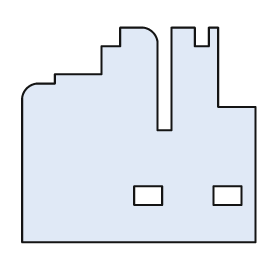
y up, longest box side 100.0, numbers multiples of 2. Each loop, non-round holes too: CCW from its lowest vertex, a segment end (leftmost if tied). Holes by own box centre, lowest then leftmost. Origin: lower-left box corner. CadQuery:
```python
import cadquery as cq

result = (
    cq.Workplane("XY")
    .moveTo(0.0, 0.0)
    .lineTo(100.0, 0.0)
    .lineTo(100.0, 58.0)
    .lineTo(84.0, 58.0)
    .lineTo(84.0, 92.0)
    .lineTo(80.0, 92.0)
    .lineTo(80.0, 84.0)
    .lineTo(74.0, 84.0)
    .lineTo(74.0, 92.0)
    .lineTo(64.0, 92.0)
    .lineTo(64.0, 48.0)
    .lineTo(58.0, 48.0)
    .lineTo(58.0, 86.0)
    .threePointArc((56.0, 90.0), (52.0, 92.0))
    .lineTo(42.0, 92.0)
    .lineTo(42.0, 84.0)
    .lineTo(34.0, 84.0)
    .lineTo(34.0, 72.0)
    .lineTo(14.0, 72.0)
    .lineTo(14.0, 68.0)
    .lineTo(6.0, 68.0)
    .threePointArc((2.0, 66.0), (0.0, 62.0))
    .close()
    .moveTo(48.0, 16.0)
    .lineTo(60.0, 16.0)
    .lineTo(60.0, 24.0)
    .lineTo(48.0, 24.0)
    .close()
    .moveTo(82.0, 16.0)
    .lineTo(94.0, 16.0)
    .lineTo(94.0, 24.0)
    .lineTo(82.0, 24.0)
    .close()
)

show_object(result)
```